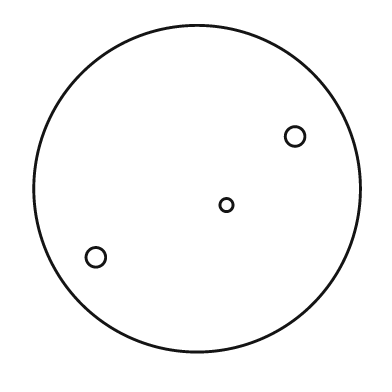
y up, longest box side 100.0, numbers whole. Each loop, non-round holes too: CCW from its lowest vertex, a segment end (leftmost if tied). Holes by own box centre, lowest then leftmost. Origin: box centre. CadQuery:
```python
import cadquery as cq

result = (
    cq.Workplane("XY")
    .moveTo(0.0, 0.0)
    .circle(50.0)
    .moveTo(-31.0, -21.0)
    .circle(3.0)
    .moveTo(9.0, -5.0)
    .circle(2.0)
    .moveTo(30.0, 16.0)
    .circle(3.0)
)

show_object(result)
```